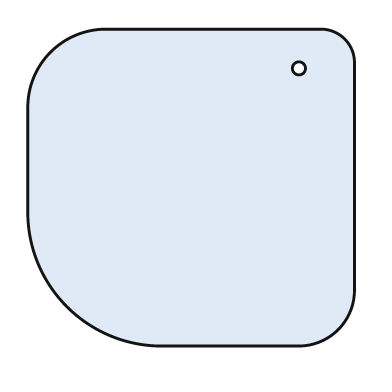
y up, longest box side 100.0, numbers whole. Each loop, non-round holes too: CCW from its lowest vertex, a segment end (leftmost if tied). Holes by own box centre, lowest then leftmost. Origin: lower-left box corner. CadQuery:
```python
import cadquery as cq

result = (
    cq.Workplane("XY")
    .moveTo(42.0, 0.0)
    .lineTo(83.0, 0.0)
    .threePointArc((95.0, 5.0), (100.0, 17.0))
    .lineTo(100.0, 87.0)
    .threePointArc((97.0, 94.0), (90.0, 97.0))
    .lineTo(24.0, 97.0)
    .threePointArc((7.0, 90.0), (0.0, 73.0))
    .lineTo(0.0, 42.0)
    .threePointArc((12.0, 12.0), (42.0, 0.0))
    .close()
    .moveTo(83.0, 85.0)
    .circle(2.0)
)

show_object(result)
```